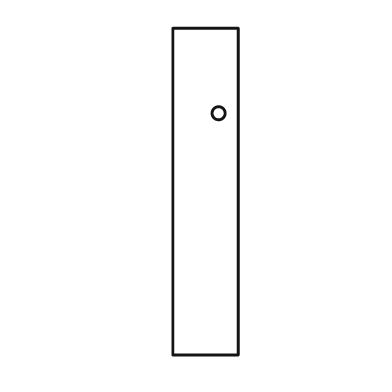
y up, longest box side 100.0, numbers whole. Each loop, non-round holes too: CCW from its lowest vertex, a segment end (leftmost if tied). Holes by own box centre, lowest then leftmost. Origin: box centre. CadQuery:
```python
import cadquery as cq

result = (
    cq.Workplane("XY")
    .moveTo(-10.0, -50.0)
    .lineTo(10.0, -50.0)
    .lineTo(10.0, 50.0)
    .lineTo(-10.0, 50.0)
    .close()
    .moveTo(4.0, 24.0)
    .circle(2.0)
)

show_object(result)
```